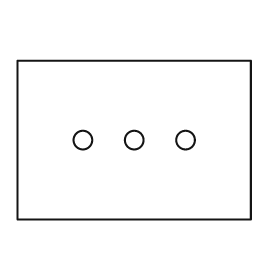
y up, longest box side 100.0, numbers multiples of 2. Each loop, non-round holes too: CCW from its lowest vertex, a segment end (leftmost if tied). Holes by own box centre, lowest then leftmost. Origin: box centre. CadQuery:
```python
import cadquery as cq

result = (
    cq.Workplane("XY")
    .moveTo(-50.0, -34.0)
    .lineTo(50.0, -34.0)
    .lineTo(50.0, 34.0)
    .lineTo(-50.0, 34.0)
    .close()
    .moveTo(-22.0, 0.0)
    .circle(4.0)
    .moveTo(0.0, 0.0)
    .circle(4.0)
    .moveTo(22.0, 0.0)
    .circle(4.0)
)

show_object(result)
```